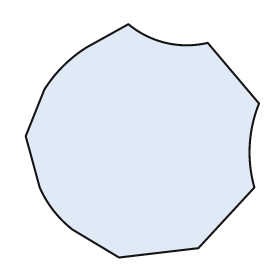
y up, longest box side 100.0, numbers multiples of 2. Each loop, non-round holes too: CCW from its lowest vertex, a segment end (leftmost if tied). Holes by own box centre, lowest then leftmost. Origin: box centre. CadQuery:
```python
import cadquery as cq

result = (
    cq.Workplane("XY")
    .moveTo(-10.0, -50.0)
    .lineTo(24.0, -46.0)
    .lineTo(48.0, -20.0)
    .threePointArc((46.0, -2.0), (50.0, 16.0))
    .lineTo(28.0, 42.0)
    .threePointArc((10.0, 42.0), (-6.0, 50.0))
    .lineTo(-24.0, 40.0)
    .threePointArc((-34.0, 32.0), (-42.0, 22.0))
    .lineTo(-50.0, 2.0)
    .lineTo(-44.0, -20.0)
    .threePointArc((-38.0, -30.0), (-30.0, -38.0))
    .close()
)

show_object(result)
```